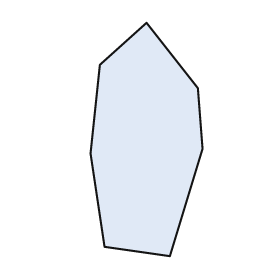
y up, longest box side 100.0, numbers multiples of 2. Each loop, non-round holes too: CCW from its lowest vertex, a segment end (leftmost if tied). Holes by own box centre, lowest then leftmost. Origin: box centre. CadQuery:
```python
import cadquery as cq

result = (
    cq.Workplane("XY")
    .moveTo(10.0, -50.0)
    .lineTo(24.0, -4.0)
    .lineTo(22.0, 22.0)
    .lineTo(0.0, 50.0)
    .lineTo(-20.0, 32.0)
    .lineTo(-24.0, -6.0)
    .lineTo(-18.0, -46.0)
    .close()
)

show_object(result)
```